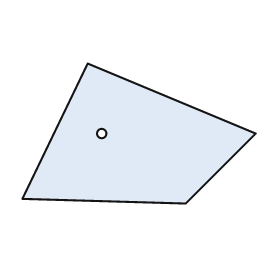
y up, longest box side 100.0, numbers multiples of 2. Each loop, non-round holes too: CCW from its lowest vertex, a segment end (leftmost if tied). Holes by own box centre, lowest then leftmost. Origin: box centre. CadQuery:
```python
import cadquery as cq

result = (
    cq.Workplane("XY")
    .moveTo(20.0, -30.0)
    .lineTo(50.0, 0.0)
    .lineTo(-22.0, 30.0)
    .lineTo(-50.0, -28.0)
    .close()
    .moveTo(-16.0, 0.0)
    .circle(2.0)
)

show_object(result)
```